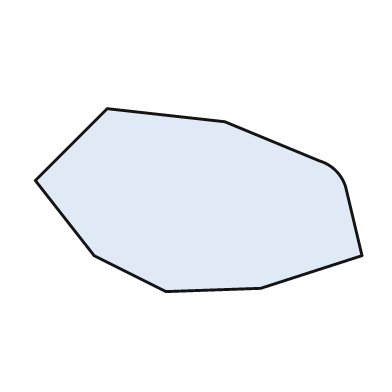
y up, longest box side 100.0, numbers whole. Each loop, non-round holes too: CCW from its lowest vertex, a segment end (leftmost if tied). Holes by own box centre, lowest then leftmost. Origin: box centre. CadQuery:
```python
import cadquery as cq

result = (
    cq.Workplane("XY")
    .moveTo(-10.0, -28.0)
    .lineTo(19.0, -27.0)
    .lineTo(50.0, -17.0)
    .lineTo(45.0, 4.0)
    .threePointArc((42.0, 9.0), (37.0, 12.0))
    .lineTo(8.0, 24.0)
    .lineTo(-28.0, 28.0)
    .lineTo(-50.0, 6.0)
    .lineTo(-32.0, -17.0)
    .close()
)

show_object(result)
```